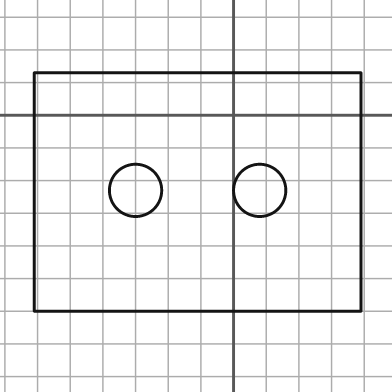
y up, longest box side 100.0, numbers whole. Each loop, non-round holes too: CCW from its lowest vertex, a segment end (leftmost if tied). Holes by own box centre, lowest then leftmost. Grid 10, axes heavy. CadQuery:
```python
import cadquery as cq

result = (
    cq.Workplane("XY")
    .moveTo(-61.0, -60.0)
    .lineTo(39.0, -60.0)
    .lineTo(39.0, 13.0)
    .lineTo(-61.0, 13.0)
    .close()
    .moveTo(-30.0, -23.0)
    .circle(8.0)
    .moveTo(8.0, -23.0)
    .circle(8.0)
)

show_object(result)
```